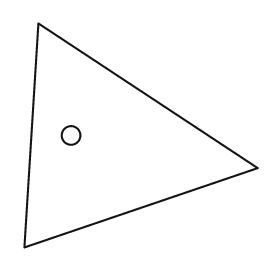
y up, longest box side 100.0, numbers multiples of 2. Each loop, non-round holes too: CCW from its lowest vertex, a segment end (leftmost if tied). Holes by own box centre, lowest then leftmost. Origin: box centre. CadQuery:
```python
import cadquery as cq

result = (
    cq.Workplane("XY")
    .moveTo(-50.0, -48.0)
    .lineTo(50.0, -14.0)
    .lineTo(-44.0, 48.0)
    .close()
    .moveTo(-30.0, 0.0)
    .circle(4.0)
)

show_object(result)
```